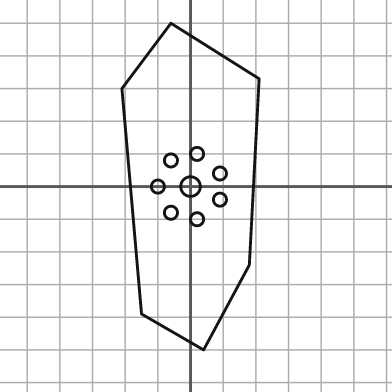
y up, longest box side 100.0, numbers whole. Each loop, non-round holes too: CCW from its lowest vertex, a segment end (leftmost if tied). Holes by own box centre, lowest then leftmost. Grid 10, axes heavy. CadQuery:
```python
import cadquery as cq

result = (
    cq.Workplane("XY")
    .moveTo(4.0, -50.0)
    .lineTo(18.0, -24.0)
    .lineTo(21.0, 33.0)
    .lineTo(-6.0, 50.0)
    .lineTo(-21.0, 30.0)
    .lineTo(-15.0, -39.0)
    .close()
    .moveTo(2.0, -10.0)
    .circle(2.0)
    .moveTo(-6.0, -8.0)
    .circle(2.0)
    .moveTo(9.0, -4.0)
    .circle(2.0)
    .moveTo(-10.0, 0.0)
    .circle(2.0)
    .moveTo(0.0, 0.0)
    .circle(3.0)
    .moveTo(9.0, 4.0)
    .circle(2.0)
    .moveTo(-6.0, 8.0)
    .circle(2.0)
    .moveTo(2.0, 10.0)
    .circle(2.0)
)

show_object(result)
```